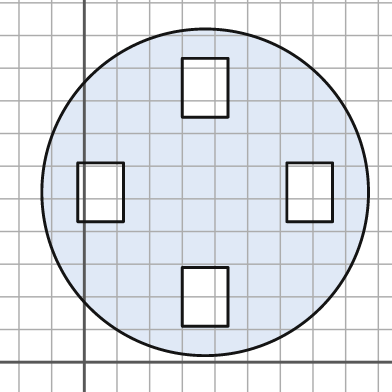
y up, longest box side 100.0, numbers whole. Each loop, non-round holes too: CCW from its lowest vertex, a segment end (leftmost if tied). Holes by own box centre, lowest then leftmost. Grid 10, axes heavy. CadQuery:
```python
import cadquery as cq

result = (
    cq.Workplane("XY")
    .moveTo(37.0, 52.0)
    .circle(50.0)
    .moveTo(30.0, 11.0)
    .lineTo(44.0, 11.0)
    .lineTo(44.0, 29.0)
    .lineTo(30.0, 29.0)
    .close()
    .moveTo(-2.0, 43.0)
    .lineTo(12.0, 43.0)
    .lineTo(12.0, 61.0)
    .lineTo(-2.0, 61.0)
    .close()
    .moveTo(62.0, 43.0)
    .lineTo(76.0, 43.0)
    .lineTo(76.0, 61.0)
    .lineTo(62.0, 61.0)
    .close()
    .moveTo(30.0, 75.0)
    .lineTo(44.0, 75.0)
    .lineTo(44.0, 93.0)
    .lineTo(30.0, 93.0)
    .close()
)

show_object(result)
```